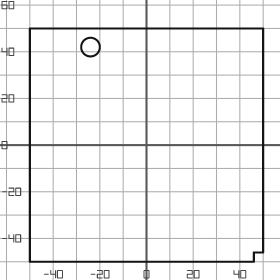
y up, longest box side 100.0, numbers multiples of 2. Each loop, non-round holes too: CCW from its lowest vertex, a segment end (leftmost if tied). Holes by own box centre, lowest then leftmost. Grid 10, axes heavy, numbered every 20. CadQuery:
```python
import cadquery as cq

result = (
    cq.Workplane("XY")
    .moveTo(-50.0, -50.0)
    .lineTo(46.0, -50.0)
    .lineTo(46.0, -46.0)
    .lineTo(50.0, -46.0)
    .lineTo(50.0, 50.0)
    .lineTo(-50.0, 50.0)
    .close()
    .moveTo(-24.0, 42.0)
    .circle(4.0)
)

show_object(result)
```